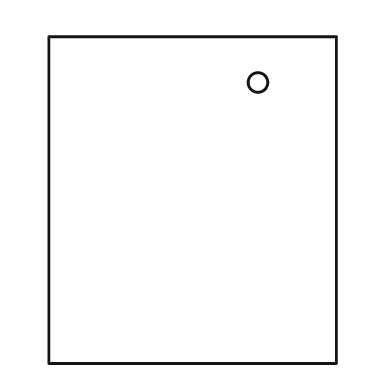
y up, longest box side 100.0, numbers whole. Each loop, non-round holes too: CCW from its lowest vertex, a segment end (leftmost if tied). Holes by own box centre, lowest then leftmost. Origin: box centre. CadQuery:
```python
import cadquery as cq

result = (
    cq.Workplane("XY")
    .moveTo(-44.0, -50.0)
    .lineTo(44.0, -50.0)
    .lineTo(44.0, 50.0)
    .lineTo(-44.0, 50.0)
    .close()
    .moveTo(20.0, 36.0)
    .circle(3.0)
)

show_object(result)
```